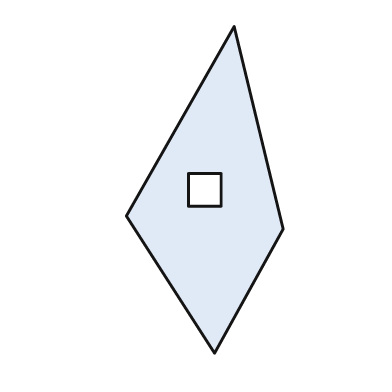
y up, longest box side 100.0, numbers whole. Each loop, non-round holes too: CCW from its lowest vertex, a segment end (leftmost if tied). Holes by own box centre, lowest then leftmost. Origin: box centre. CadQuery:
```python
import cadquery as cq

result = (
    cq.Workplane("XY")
    .moveTo(3.0, -50.0)
    .lineTo(24.0, -12.0)
    .lineTo(9.0, 50.0)
    .lineTo(-24.0, -8.0)
    .close()
    .moveTo(-5.0, -5.0)
    .lineTo(5.0, -5.0)
    .lineTo(5.0, 5.0)
    .lineTo(-5.0, 5.0)
    .close()
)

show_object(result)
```